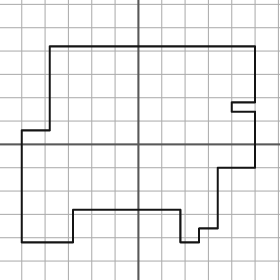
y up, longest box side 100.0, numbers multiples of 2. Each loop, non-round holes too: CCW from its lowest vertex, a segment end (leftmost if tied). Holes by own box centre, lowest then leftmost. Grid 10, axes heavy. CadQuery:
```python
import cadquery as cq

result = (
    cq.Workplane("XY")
    .moveTo(-50.0, -42.0)
    .lineTo(-28.0, -42.0)
    .lineTo(-28.0, -28.0)
    .lineTo(18.0, -28.0)
    .lineTo(18.0, -42.0)
    .lineTo(26.0, -42.0)
    .lineTo(26.0, -36.0)
    .lineTo(34.0, -36.0)
    .lineTo(34.0, -10.0)
    .lineTo(50.0, -10.0)
    .lineTo(50.0, 14.0)
    .lineTo(40.0, 14.0)
    .lineTo(40.0, 18.0)
    .lineTo(50.0, 18.0)
    .lineTo(50.0, 42.0)
    .lineTo(-38.0, 42.0)
    .lineTo(-38.0, 6.0)
    .lineTo(-50.0, 6.0)
    .close()
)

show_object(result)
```